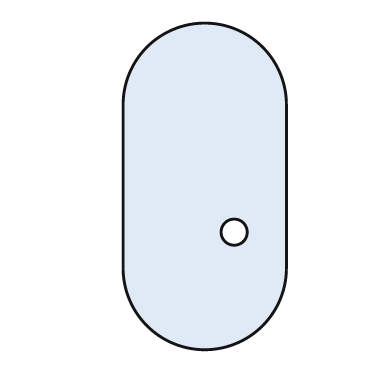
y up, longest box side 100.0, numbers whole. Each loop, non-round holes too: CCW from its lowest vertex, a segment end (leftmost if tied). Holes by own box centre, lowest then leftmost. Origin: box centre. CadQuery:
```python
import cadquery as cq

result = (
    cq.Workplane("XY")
    .moveTo(-25.0, -25.0)
    .threePointArc((0.0, -50.0), (25.0, -25.0))
    .lineTo(25.0, 25.0)
    .threePointArc((0.0, 50.0), (-25.0, 25.0))
    .close()
    .moveTo(9.0, -14.0)
    .circle(4.0)
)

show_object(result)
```